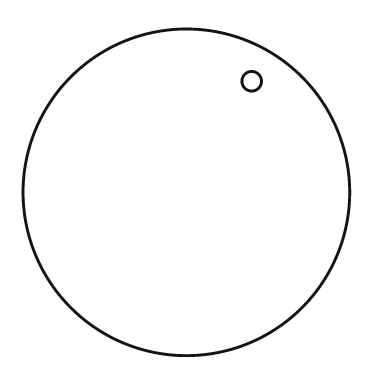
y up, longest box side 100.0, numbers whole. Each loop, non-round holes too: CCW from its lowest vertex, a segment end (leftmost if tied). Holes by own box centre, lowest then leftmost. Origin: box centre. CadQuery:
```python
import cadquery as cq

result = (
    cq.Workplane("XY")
    .moveTo(0.0, 0.0)
    .circle(50.0)
    .moveTo(20.0, 34.0)
    .circle(3.0)
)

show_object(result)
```